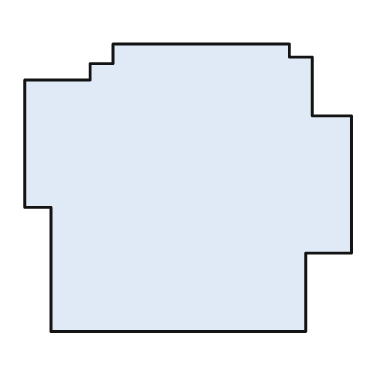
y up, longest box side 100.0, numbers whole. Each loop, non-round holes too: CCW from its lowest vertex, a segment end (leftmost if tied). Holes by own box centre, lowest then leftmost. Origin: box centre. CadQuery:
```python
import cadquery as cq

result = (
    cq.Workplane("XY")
    .moveTo(-42.0, -44.0)
    .lineTo(36.0, -44.0)
    .lineTo(36.0, -20.0)
    .lineTo(50.0, -20.0)
    .lineTo(50.0, 22.0)
    .lineTo(38.0, 22.0)
    .lineTo(38.0, 40.0)
    .lineTo(31.0, 40.0)
    .lineTo(31.0, 44.0)
    .lineTo(-23.0, 44.0)
    .lineTo(-23.0, 38.0)
    .lineTo(-30.0, 38.0)
    .lineTo(-30.0, 33.0)
    .lineTo(-50.0, 33.0)
    .lineTo(-50.0, -6.0)
    .lineTo(-42.0, -6.0)
    .close()
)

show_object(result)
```